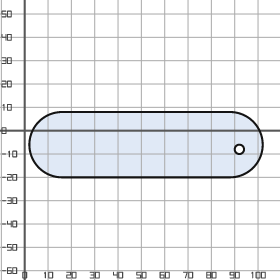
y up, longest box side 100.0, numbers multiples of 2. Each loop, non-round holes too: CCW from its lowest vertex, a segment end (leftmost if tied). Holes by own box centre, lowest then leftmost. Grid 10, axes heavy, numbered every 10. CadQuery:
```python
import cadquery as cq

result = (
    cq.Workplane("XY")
    .moveTo(16.0, -20.0)
    .lineTo(88.0, -20.0)
    .threePointArc((102.0, -6.0), (88.0, 8.0))
    .lineTo(16.0, 8.0)
    .threePointArc((2.0, -6.0), (16.0, -20.0))
    .close()
    .moveTo(92.0, -8.0)
    .circle(2.0)
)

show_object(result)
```